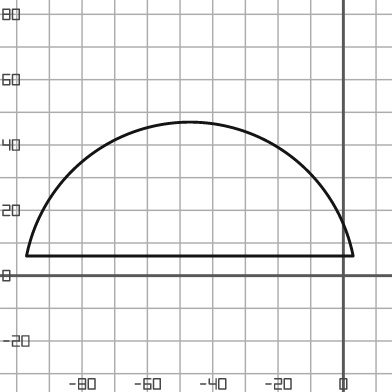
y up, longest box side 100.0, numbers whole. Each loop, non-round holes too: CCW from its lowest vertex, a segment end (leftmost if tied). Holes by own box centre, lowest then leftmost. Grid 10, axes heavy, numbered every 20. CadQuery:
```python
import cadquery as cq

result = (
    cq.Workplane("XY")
    .moveTo(-97.0, 6.0)
    .lineTo(3.0, 6.0)
    .threePointArc((-47.0, 47.0), (-97.0, 6.0))
    .close()
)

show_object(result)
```